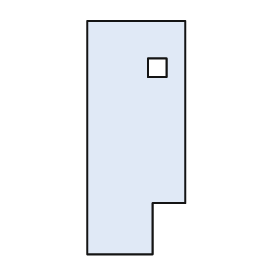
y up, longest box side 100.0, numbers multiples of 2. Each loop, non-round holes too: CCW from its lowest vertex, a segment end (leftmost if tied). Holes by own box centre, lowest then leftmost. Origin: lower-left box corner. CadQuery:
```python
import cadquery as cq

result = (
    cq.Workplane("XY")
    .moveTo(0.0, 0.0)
    .lineTo(28.0, 0.0)
    .lineTo(28.0, 22.0)
    .lineTo(42.0, 22.0)
    .lineTo(42.0, 100.0)
    .lineTo(0.0, 100.0)
    .close()
    .moveTo(26.0, 76.0)
    .lineTo(34.0, 76.0)
    .lineTo(34.0, 84.0)
    .lineTo(26.0, 84.0)
    .close()
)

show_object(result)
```